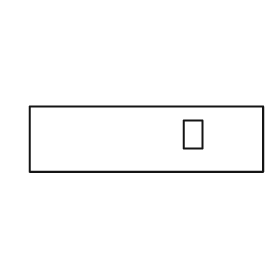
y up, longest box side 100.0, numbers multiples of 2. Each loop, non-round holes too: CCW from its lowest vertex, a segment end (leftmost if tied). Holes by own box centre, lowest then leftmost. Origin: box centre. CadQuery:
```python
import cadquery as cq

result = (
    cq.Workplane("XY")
    .moveTo(-50.0, -14.0)
    .lineTo(50.0, -14.0)
    .lineTo(50.0, 14.0)
    .lineTo(-50.0, 14.0)
    .close()
    .moveTo(16.0, -4.0)
    .lineTo(24.0, -4.0)
    .lineTo(24.0, 8.0)
    .lineTo(16.0, 8.0)
    .close()
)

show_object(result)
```